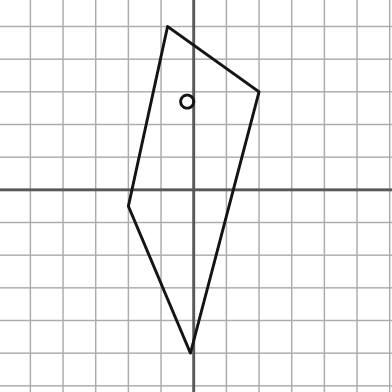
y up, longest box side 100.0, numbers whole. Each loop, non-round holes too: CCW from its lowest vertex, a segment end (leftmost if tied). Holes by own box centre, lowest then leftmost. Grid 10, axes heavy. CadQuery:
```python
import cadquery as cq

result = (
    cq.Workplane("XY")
    .moveTo(-1.0, -50.0)
    .lineTo(20.0, 30.0)
    .lineTo(-8.0, 50.0)
    .lineTo(-20.0, -5.0)
    .close()
    .moveTo(-2.0, 27.0)
    .circle(2.0)
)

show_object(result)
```